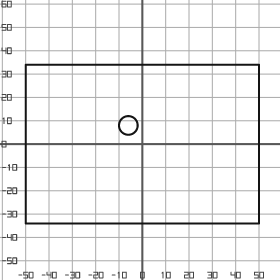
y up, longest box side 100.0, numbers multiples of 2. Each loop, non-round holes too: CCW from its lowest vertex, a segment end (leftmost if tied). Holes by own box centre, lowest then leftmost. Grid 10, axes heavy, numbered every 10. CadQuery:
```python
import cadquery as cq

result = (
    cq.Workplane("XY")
    .moveTo(-50.0, -34.0)
    .lineTo(50.0, -34.0)
    .lineTo(50.0, 34.0)
    .lineTo(-50.0, 34.0)
    .close()
    .moveTo(-6.0, 8.0)
    .circle(4.0)
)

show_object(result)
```